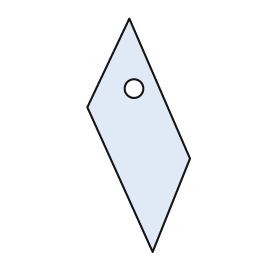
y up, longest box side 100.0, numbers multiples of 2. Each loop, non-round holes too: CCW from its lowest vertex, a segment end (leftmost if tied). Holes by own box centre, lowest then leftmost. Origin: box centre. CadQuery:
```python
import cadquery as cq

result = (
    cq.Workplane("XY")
    .moveTo(6.0, -50.0)
    .lineTo(22.0, -10.0)
    .lineTo(-4.0, 50.0)
    .lineTo(-22.0, 12.0)
    .close()
    .moveTo(-2.0, 20.0)
    .circle(4.0)
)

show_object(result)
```